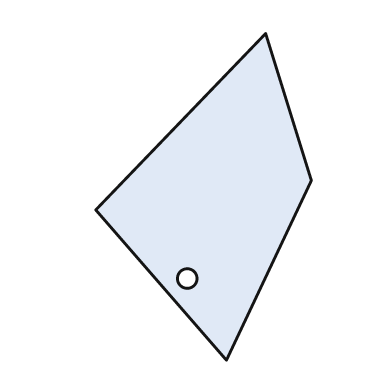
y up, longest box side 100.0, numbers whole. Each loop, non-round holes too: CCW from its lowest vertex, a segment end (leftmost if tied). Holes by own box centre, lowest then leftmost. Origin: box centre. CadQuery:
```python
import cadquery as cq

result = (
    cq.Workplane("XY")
    .moveTo(7.0, -50.0)
    .lineTo(33.0, 5.0)
    .lineTo(19.0, 50.0)
    .lineTo(-33.0, -4.0)
    .close()
    .moveTo(-5.0, -25.0)
    .circle(3.0)
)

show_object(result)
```